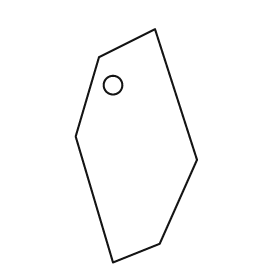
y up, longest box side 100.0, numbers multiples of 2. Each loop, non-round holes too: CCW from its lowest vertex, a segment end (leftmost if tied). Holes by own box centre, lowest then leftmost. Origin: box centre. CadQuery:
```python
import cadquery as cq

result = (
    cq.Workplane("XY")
    .moveTo(-10.0, -50.0)
    .lineTo(10.0, -42.0)
    .lineTo(26.0, -6.0)
    .lineTo(8.0, 50.0)
    .lineTo(-16.0, 38.0)
    .lineTo(-26.0, 4.0)
    .close()
    .moveTo(-10.0, 26.0)
    .circle(4.0)
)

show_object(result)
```